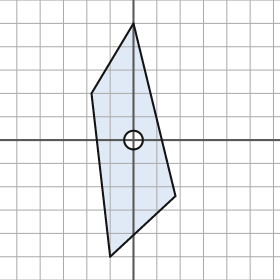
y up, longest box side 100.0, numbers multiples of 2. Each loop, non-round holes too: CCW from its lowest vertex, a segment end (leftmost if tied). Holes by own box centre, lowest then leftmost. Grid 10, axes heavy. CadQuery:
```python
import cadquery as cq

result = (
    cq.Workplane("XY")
    .moveTo(-10.0, -50.0)
    .lineTo(18.0, -24.0)
    .lineTo(0.0, 50.0)
    .lineTo(-18.0, 20.0)
    .close()
    .moveTo(0.0, 0.0)
    .circle(4.0)
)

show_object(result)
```